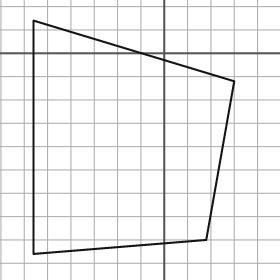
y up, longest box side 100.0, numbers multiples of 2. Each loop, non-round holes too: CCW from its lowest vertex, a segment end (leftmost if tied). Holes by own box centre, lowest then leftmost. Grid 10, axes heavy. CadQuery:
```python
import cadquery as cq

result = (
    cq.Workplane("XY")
    .moveTo(-56.0, -86.0)
    .lineTo(18.0, -80.0)
    .lineTo(30.0, -12.0)
    .lineTo(-56.0, 14.0)
    .close()
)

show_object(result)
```